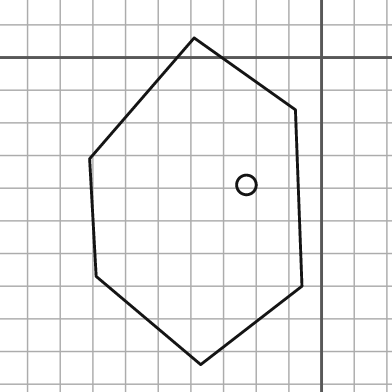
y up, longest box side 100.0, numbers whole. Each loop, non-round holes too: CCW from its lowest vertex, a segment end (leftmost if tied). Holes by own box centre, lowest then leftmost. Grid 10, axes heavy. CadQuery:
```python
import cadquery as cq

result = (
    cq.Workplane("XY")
    .moveTo(-37.0, -94.0)
    .lineTo(-6.0, -70.0)
    .lineTo(-8.0, -16.0)
    .lineTo(-39.0, 6.0)
    .lineTo(-71.0, -31.0)
    .lineTo(-69.0, -67.0)
    .close()
    .moveTo(-23.0, -39.0)
    .circle(3.0)
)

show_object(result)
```